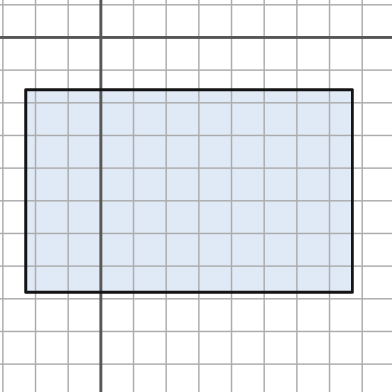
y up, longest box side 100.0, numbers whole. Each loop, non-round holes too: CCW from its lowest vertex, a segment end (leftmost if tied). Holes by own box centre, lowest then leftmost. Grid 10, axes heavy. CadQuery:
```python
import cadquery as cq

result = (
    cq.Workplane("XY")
    .moveTo(-23.0, -78.0)
    .lineTo(77.0, -78.0)
    .lineTo(77.0, -16.0)
    .lineTo(-23.0, -16.0)
    .close()
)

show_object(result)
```